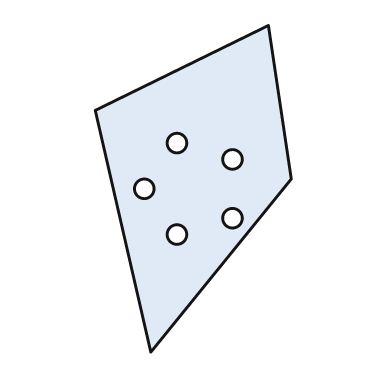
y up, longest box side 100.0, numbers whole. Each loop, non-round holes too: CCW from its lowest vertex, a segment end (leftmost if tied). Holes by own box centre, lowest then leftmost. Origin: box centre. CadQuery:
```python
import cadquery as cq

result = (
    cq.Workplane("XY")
    .moveTo(-13.0, -50.0)
    .lineTo(30.0, 3.0)
    .lineTo(23.0, 50.0)
    .lineTo(-30.0, 24.0)
    .close()
    .moveTo(-5.0, -14.0)
    .circle(3.0)
    .moveTo(12.0, -9.0)
    .circle(3.0)
    .moveTo(-15.0, 0.0)
    .circle(3.0)
    .moveTo(12.0, 9.0)
    .circle(3.0)
    .moveTo(-5.0, 14.0)
    .circle(3.0)
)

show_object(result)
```